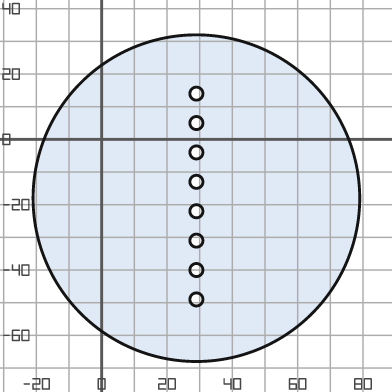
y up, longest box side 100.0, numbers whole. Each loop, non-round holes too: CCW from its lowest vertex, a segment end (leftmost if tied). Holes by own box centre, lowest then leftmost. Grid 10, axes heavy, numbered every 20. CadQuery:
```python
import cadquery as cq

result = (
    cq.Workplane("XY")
    .moveTo(29.0, -18.0)
    .circle(50.0)
    .moveTo(29.0, -49.0)
    .circle(2.0)
    .moveTo(29.0, -40.0)
    .circle(2.0)
    .moveTo(29.0, -31.0)
    .circle(2.0)
    .moveTo(29.0, -22.0)
    .circle(2.0)
    .moveTo(29.0, -13.0)
    .circle(2.0)
    .moveTo(29.0, -4.0)
    .circle(2.0)
    .moveTo(29.0, 5.0)
    .circle(2.0)
    .moveTo(29.0, 14.0)
    .circle(2.0)
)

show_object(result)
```